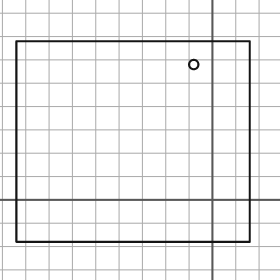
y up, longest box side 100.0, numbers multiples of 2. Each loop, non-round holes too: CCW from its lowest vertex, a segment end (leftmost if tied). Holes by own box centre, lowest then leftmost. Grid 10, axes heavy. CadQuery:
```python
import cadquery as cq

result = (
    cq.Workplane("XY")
    .moveTo(-84.0, -18.0)
    .lineTo(16.0, -18.0)
    .lineTo(16.0, 68.0)
    .lineTo(-84.0, 68.0)
    .close()
    .moveTo(-8.0, 58.0)
    .circle(2.0)
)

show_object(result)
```